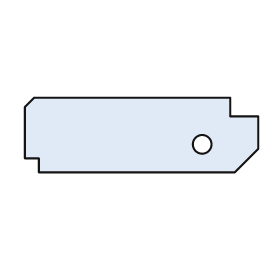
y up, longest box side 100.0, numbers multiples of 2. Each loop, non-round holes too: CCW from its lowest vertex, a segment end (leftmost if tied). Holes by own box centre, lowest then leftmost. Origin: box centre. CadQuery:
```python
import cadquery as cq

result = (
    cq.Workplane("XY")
    .moveTo(-44.0, -16.0)
    .lineTo(40.0, -16.0)
    .lineTo(50.0, -6.0)
    .lineTo(50.0, 8.0)
    .lineTo(38.0, 8.0)
    .lineTo(38.0, 16.0)
    .lineTo(-46.0, 16.0)
    .lineTo(-50.0, 12.0)
    .lineTo(-50.0, -10.0)
    .lineTo(-44.0, -10.0)
    .close()
    .moveTo(26.0, -4.0)
    .circle(4.0)
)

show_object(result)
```